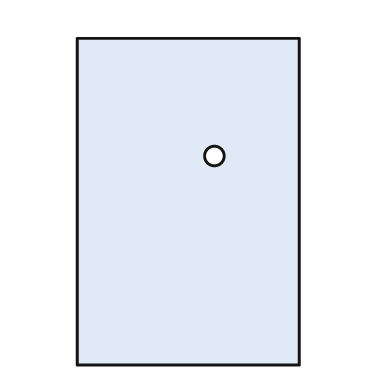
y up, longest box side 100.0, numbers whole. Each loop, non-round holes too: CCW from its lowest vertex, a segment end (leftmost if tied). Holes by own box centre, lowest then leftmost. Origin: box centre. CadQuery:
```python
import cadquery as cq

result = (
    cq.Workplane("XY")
    .moveTo(-34.0, -50.0)
    .lineTo(34.0, -50.0)
    .lineTo(34.0, 50.0)
    .lineTo(-34.0, 50.0)
    .close()
    .moveTo(8.0, 14.0)
    .circle(3.0)
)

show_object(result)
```